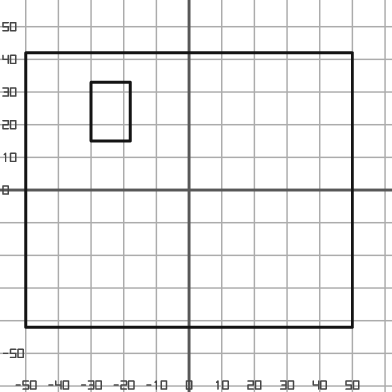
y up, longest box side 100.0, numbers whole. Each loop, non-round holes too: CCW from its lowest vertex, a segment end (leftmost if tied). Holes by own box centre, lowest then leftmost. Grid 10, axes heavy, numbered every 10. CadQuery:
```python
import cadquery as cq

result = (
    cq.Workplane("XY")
    .moveTo(-50.0, -42.0)
    .lineTo(50.0, -42.0)
    .lineTo(50.0, 42.0)
    .lineTo(-50.0, 42.0)
    .close()
    .moveTo(-30.0, 15.0)
    .lineTo(-18.0, 15.0)
    .lineTo(-18.0, 33.0)
    .lineTo(-30.0, 33.0)
    .close()
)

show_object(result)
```